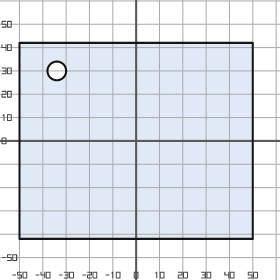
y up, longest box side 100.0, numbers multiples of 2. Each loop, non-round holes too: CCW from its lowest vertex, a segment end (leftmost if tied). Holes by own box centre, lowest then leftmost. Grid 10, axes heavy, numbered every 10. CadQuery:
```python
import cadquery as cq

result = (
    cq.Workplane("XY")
    .moveTo(-50.0, -42.0)
    .lineTo(50.0, -42.0)
    .lineTo(50.0, 42.0)
    .lineTo(-50.0, 42.0)
    .close()
    .moveTo(-34.0, 30.0)
    .circle(4.0)
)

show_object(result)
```